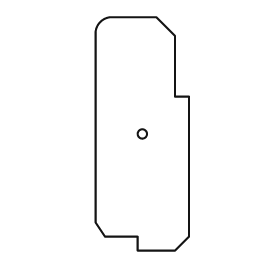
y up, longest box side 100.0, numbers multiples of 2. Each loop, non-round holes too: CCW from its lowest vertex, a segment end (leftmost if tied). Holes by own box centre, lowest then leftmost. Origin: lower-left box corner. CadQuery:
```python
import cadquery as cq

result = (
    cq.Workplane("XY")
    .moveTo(18.0, 0.0)
    .lineTo(34.0, 0.0)
    .lineTo(40.0, 6.0)
    .lineTo(40.0, 66.0)
    .lineTo(34.0, 66.0)
    .lineTo(34.0, 92.0)
    .lineTo(26.0, 100.0)
    .lineTo(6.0, 100.0)
    .threePointArc((2.0, 98.0), (0.0, 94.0))
    .lineTo(0.0, 12.0)
    .lineTo(4.0, 6.0)
    .lineTo(18.0, 6.0)
    .close()
    .moveTo(20.0, 50.0)
    .circle(2.0)
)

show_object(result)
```